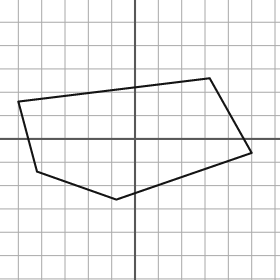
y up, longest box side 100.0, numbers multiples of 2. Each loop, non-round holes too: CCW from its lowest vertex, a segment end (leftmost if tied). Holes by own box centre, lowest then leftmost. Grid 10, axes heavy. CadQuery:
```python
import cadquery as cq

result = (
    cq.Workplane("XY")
    .moveTo(-8.0, -26.0)
    .lineTo(50.0, -6.0)
    .lineTo(32.0, 26.0)
    .lineTo(-50.0, 16.0)
    .lineTo(-42.0, -14.0)
    .close()
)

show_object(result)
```